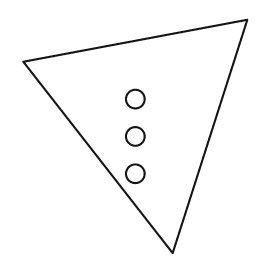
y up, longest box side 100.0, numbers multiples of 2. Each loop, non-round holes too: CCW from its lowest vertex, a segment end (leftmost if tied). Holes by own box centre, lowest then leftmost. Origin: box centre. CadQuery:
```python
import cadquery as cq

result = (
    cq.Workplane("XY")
    .moveTo(16.0, -50.0)
    .lineTo(48.0, 50.0)
    .lineTo(-48.0, 32.0)
    .close()
    .moveTo(0.0, -16.0)
    .circle(4.0)
    .moveTo(0.0, 0.0)
    .circle(4.0)
    .moveTo(0.0, 16.0)
    .circle(4.0)
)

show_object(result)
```